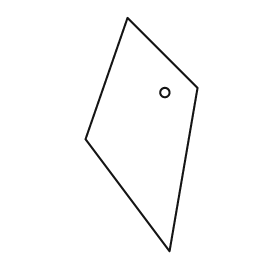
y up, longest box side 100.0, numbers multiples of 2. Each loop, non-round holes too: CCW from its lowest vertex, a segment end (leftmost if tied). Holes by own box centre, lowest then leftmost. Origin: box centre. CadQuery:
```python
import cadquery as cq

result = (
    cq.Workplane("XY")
    .moveTo(12.0, -50.0)
    .lineTo(24.0, 20.0)
    .lineTo(-6.0, 50.0)
    .lineTo(-24.0, -2.0)
    .close()
    .moveTo(10.0, 18.0)
    .circle(2.0)
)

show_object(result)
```